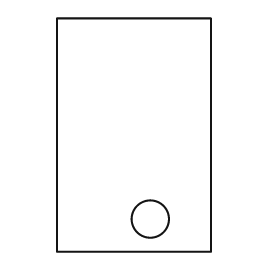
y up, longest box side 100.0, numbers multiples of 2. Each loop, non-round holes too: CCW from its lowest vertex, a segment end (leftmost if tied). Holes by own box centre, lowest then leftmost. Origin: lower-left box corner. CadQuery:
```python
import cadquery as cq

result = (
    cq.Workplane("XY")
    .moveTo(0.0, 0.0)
    .lineTo(66.0, 0.0)
    .lineTo(66.0, 100.0)
    .lineTo(0.0, 100.0)
    .close()
    .moveTo(40.0, 14.0)
    .circle(8.0)
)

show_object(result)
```